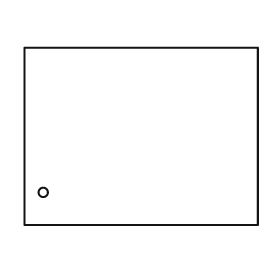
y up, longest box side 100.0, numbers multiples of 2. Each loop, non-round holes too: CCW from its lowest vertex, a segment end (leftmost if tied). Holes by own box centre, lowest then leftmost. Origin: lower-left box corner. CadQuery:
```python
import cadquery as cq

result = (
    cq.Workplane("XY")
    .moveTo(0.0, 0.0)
    .lineTo(100.0, 0.0)
    .lineTo(100.0, 76.0)
    .lineTo(0.0, 76.0)
    .close()
    .moveTo(8.0, 14.0)
    .circle(2.0)
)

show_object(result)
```